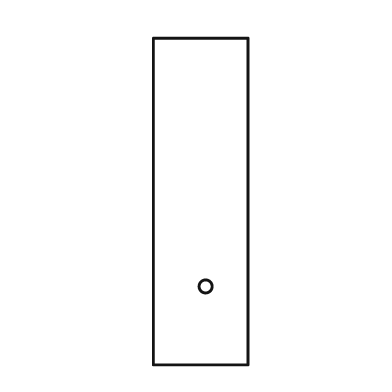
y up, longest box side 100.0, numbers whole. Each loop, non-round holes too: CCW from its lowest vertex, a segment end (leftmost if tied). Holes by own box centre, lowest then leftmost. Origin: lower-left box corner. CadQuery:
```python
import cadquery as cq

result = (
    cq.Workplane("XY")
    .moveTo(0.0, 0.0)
    .lineTo(29.0, 0.0)
    .lineTo(29.0, 100.0)
    .lineTo(0.0, 100.0)
    .close()
    .moveTo(16.0, 24.0)
    .circle(2.0)
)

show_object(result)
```